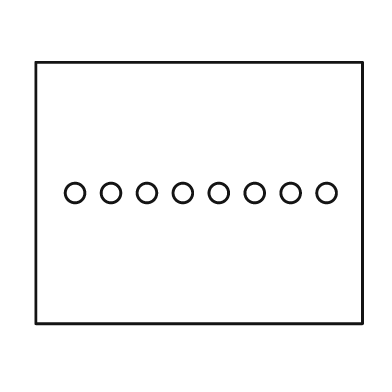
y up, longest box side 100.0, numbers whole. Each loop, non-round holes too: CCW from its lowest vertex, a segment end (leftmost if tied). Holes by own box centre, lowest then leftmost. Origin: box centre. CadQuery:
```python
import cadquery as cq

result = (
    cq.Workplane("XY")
    .moveTo(-50.0, -40.0)
    .lineTo(50.0, -40.0)
    .lineTo(50.0, 40.0)
    .lineTo(-50.0, 40.0)
    .close()
    .moveTo(-38.0, 0.0)
    .circle(3.0)
    .moveTo(-27.0, 0.0)
    .circle(3.0)
    .moveTo(-16.0, 0.0)
    .circle(3.0)
    .moveTo(-5.0, 0.0)
    .circle(3.0)
    .moveTo(6.0, 0.0)
    .circle(3.0)
    .moveTo(17.0, 0.0)
    .circle(3.0)
    .moveTo(28.0, 0.0)
    .circle(3.0)
    .moveTo(39.0, 0.0)
    .circle(3.0)
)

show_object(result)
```